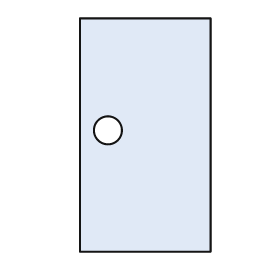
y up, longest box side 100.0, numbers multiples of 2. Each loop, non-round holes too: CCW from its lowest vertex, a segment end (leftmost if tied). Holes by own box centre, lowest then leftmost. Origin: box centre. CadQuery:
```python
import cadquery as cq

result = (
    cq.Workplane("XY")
    .moveTo(-28.0, -50.0)
    .lineTo(28.0, -50.0)
    .lineTo(28.0, 50.0)
    .lineTo(-28.0, 50.0)
    .close()
    .moveTo(-16.0, 2.0)
    .circle(6.0)
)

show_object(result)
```